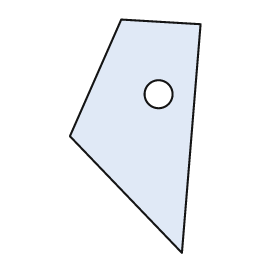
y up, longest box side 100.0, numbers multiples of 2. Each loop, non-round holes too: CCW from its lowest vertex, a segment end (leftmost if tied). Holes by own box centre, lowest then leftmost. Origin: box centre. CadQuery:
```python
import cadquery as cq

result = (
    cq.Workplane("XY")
    .moveTo(20.0, -50.0)
    .lineTo(28.0, 48.0)
    .lineTo(-6.0, 50.0)
    .lineTo(-28.0, 0.0)
    .close()
    .moveTo(10.0, 18.0)
    .circle(6.0)
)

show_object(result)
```